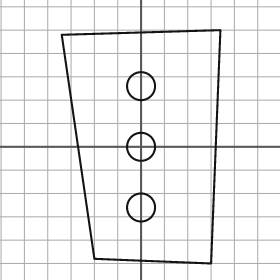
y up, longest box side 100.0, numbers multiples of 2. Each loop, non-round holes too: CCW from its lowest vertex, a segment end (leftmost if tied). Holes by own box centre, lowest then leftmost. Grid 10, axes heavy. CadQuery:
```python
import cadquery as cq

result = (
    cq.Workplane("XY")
    .moveTo(30.0, -50.0)
    .lineTo(34.0, 50.0)
    .lineTo(-34.0, 48.0)
    .lineTo(-20.0, -48.0)
    .close()
    .moveTo(0.0, -26.0)
    .circle(6.0)
    .moveTo(0.0, 0.0)
    .circle(6.0)
    .moveTo(0.0, 26.0)
    .circle(6.0)
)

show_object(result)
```